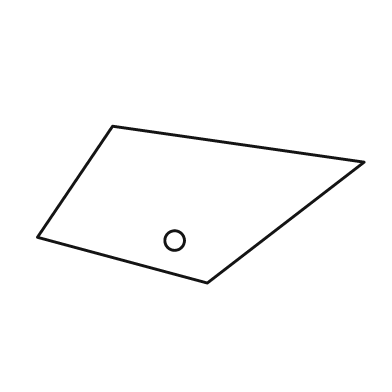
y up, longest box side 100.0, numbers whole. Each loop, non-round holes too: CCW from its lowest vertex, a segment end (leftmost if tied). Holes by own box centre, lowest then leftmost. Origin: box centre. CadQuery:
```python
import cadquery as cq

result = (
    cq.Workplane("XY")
    .moveTo(2.0, -24.0)
    .lineTo(50.0, 13.0)
    .lineTo(-27.0, 24.0)
    .lineTo(-50.0, -10.0)
    .close()
    .moveTo(-8.0, -11.0)
    .circle(3.0)
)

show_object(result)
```